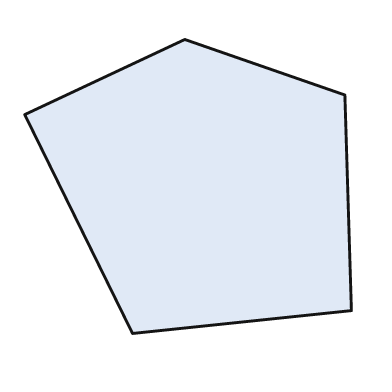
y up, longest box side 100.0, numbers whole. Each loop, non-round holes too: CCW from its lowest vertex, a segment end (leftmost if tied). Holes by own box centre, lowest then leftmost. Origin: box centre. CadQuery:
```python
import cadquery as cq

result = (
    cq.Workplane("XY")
    .moveTo(-17.0, -45.0)
    .lineTo(50.0, -38.0)
    .lineTo(48.0, 28.0)
    .lineTo(-1.0, 45.0)
    .lineTo(-50.0, 22.0)
    .close()
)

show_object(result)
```